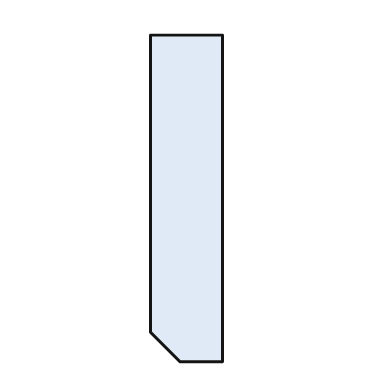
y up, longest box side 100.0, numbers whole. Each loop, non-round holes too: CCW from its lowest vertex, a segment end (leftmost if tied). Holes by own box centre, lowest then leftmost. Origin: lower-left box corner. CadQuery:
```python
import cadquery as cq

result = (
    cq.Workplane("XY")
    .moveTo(9.0, 0.0)
    .lineTo(22.0, 0.0)
    .lineTo(22.0, 100.0)
    .lineTo(0.0, 100.0)
    .lineTo(0.0, 9.0)
    .close()
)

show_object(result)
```